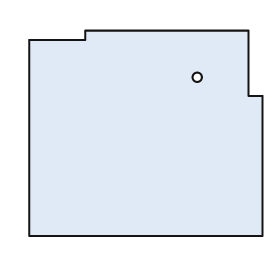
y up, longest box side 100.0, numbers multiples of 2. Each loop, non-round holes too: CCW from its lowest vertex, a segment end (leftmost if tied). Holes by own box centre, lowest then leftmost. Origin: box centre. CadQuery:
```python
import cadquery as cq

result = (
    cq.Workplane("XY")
    .moveTo(-50.0, -44.0)
    .lineTo(50.0, -44.0)
    .lineTo(50.0, 16.0)
    .lineTo(44.0, 16.0)
    .lineTo(44.0, 44.0)
    .lineTo(-26.0, 44.0)
    .lineTo(-26.0, 40.0)
    .lineTo(-50.0, 40.0)
    .close()
    .moveTo(22.0, 24.0)
    .circle(2.0)
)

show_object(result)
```